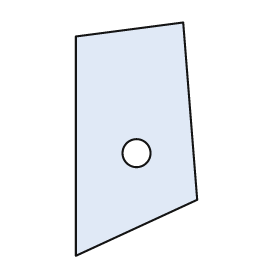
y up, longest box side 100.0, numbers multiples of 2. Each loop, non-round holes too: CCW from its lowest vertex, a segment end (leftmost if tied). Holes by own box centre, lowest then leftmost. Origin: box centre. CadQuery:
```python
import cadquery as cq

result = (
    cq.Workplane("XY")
    .moveTo(-26.0, -50.0)
    .lineTo(26.0, -26.0)
    .lineTo(20.0, 50.0)
    .lineTo(-26.0, 44.0)
    .close()
    .moveTo(0.0, -6.0)
    .circle(6.0)
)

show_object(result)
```